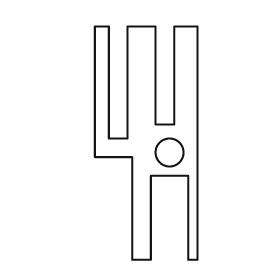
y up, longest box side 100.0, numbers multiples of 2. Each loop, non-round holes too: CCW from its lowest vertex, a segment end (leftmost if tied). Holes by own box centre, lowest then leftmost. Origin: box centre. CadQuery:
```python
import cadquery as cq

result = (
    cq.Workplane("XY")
    .moveTo(-6.0, -50.0)
    .lineTo(2.0, -50.0)
    .lineTo(2.0, -14.0)
    .lineTo(18.0, -14.0)
    .lineTo(18.0, -50.0)
    .lineTo(22.0, -50.0)
    .lineTo(22.0, 50.0)
    .lineTo(12.0, 50.0)
    .lineTo(12.0, 8.0)
    .lineTo(4.0, 8.0)
    .lineTo(4.0, 50.0)
    .lineTo(-8.0, 50.0)
    .lineTo(-8.0, 2.0)
    .lineTo(-16.0, 2.0)
    .lineTo(-16.0, 50.0)
    .lineTo(-22.0, 50.0)
    .lineTo(-22.0, -6.0)
    .lineTo(-6.0, -6.0)
    .close()
    .moveTo(10.0, -4.0)
    .circle(6.0)
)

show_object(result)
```